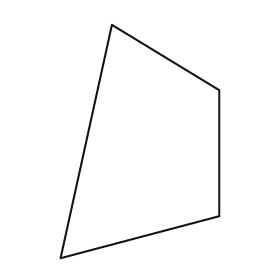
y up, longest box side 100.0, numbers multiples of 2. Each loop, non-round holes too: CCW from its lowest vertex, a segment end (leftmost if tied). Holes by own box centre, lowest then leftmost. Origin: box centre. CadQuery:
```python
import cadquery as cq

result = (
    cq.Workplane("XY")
    .moveTo(-34.0, -50.0)
    .lineTo(34.0, -32.0)
    .lineTo(34.0, 22.0)
    .lineTo(-12.0, 50.0)
    .close()
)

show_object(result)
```